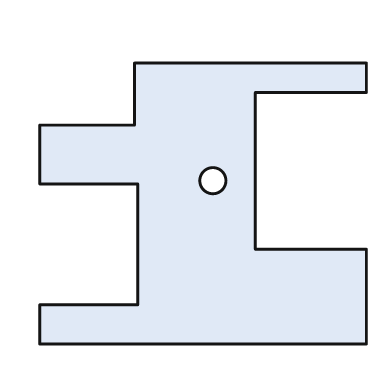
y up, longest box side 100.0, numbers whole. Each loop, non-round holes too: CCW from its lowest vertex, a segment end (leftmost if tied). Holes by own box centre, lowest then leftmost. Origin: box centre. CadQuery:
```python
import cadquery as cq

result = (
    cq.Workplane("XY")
    .moveTo(-50.0, -43.0)
    .lineTo(50.0, -43.0)
    .lineTo(50.0, -14.0)
    .lineTo(16.0, -14.0)
    .lineTo(16.0, 34.0)
    .lineTo(50.0, 34.0)
    .lineTo(50.0, 43.0)
    .lineTo(-21.0, 43.0)
    .lineTo(-21.0, 24.0)
    .lineTo(-50.0, 24.0)
    .lineTo(-50.0, 6.0)
    .lineTo(-20.0, 6.0)
    .lineTo(-20.0, -31.0)
    .lineTo(-50.0, -31.0)
    .close()
    .moveTo(3.0, 7.0)
    .circle(4.0)
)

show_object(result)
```